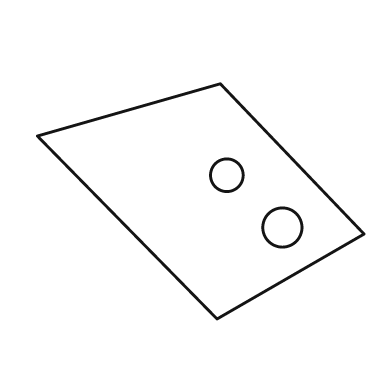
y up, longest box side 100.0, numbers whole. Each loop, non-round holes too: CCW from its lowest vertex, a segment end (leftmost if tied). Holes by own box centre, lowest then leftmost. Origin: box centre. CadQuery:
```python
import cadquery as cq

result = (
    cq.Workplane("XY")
    .moveTo(5.0, -36.0)
    .lineTo(50.0, -10.0)
    .lineTo(6.0, 36.0)
    .lineTo(-50.0, 20.0)
    .close()
    .moveTo(25.0, -8.0)
    .circle(6.0)
    .moveTo(8.0, 8.0)
    .circle(5.0)
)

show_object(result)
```